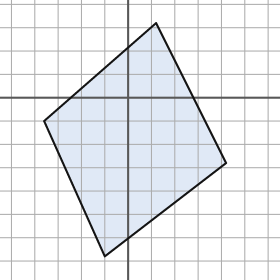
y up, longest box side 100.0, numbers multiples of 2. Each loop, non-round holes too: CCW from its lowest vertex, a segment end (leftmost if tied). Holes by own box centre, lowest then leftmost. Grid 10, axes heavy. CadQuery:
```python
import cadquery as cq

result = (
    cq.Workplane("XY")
    .moveTo(-10.0, -68.0)
    .lineTo(42.0, -28.0)
    .lineTo(12.0, 32.0)
    .lineTo(-36.0, -10.0)
    .close()
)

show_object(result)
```